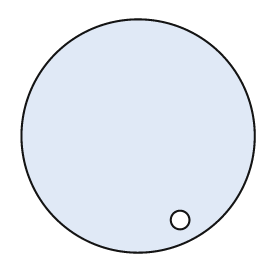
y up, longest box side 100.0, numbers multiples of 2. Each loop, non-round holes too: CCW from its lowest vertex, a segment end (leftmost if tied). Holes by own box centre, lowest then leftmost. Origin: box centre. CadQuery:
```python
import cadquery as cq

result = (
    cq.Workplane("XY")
    .moveTo(0.0, 0.0)
    .circle(50.0)
    .moveTo(18.0, -36.0)
    .circle(4.0)
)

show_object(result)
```